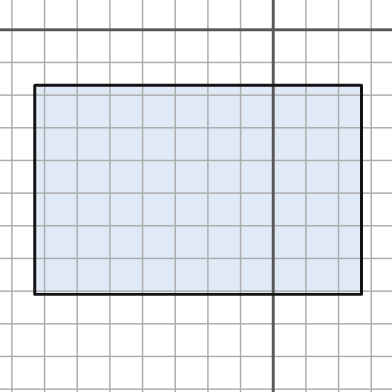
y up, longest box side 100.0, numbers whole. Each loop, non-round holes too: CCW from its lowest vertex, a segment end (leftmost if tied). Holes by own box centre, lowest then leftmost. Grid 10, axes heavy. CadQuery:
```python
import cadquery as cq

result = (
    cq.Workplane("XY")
    .moveTo(-73.0, -81.0)
    .lineTo(27.0, -81.0)
    .lineTo(27.0, -17.0)
    .lineTo(-73.0, -17.0)
    .close()
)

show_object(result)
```